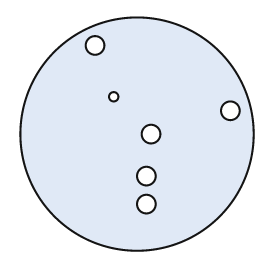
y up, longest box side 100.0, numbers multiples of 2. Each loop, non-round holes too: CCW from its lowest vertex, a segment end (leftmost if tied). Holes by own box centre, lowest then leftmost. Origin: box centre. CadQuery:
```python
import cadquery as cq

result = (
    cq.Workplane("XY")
    .moveTo(0.0, 0.0)
    .circle(50.0)
    .moveTo(4.0, -30.0)
    .circle(4.0)
    .moveTo(4.0, -18.0)
    .circle(4.0)
    .moveTo(6.0, 0.0)
    .circle(4.0)
    .moveTo(40.0, 10.0)
    .circle(4.0)
    .moveTo(-10.0, 16.0)
    .circle(2.0)
    .moveTo(-18.0, 38.0)
    .circle(4.0)
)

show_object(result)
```